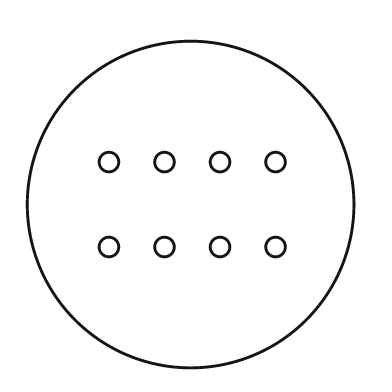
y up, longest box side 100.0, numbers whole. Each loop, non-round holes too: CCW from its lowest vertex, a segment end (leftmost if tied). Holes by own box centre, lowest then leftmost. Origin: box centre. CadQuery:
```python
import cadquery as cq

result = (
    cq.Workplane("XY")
    .moveTo(0.0, 0.0)
    .circle(50.0)
    .moveTo(-25.0, -13.0)
    .circle(3.0)
    .moveTo(-8.0, -13.0)
    .circle(3.0)
    .moveTo(9.0, -13.0)
    .circle(3.0)
    .moveTo(26.0, -13.0)
    .circle(3.0)
    .moveTo(-25.0, 13.0)
    .circle(3.0)
    .moveTo(-8.0, 13.0)
    .circle(3.0)
    .moveTo(9.0, 13.0)
    .circle(3.0)
    .moveTo(26.0, 13.0)
    .circle(3.0)
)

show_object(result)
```